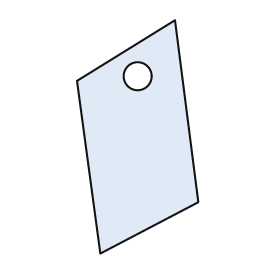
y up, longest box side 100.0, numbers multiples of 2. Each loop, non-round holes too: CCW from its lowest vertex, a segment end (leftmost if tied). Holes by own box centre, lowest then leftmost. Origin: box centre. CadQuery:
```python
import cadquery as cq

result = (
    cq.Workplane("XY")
    .moveTo(-16.0, -50.0)
    .lineTo(26.0, -28.0)
    .lineTo(16.0, 50.0)
    .lineTo(-26.0, 24.0)
    .close()
    .moveTo(0.0, 26.0)
    .circle(6.0)
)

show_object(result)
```